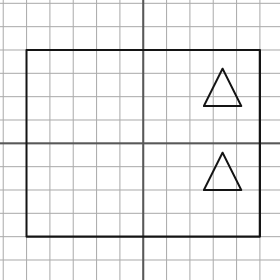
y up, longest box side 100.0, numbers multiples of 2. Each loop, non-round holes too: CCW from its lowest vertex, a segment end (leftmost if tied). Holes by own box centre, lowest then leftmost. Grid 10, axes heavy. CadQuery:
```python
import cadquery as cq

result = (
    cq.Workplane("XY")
    .moveTo(-50.0, -40.0)
    .lineTo(50.0, -40.0)
    .lineTo(50.0, 40.0)
    .lineTo(-50.0, 40.0)
    .close()
    .moveTo(26.0, -20.0)
    .lineTo(42.0, -20.0)
    .lineTo(34.0, -4.0)
    .close()
    .moveTo(26.0, 16.0)
    .lineTo(42.0, 16.0)
    .lineTo(34.0, 32.0)
    .close()
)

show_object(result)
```